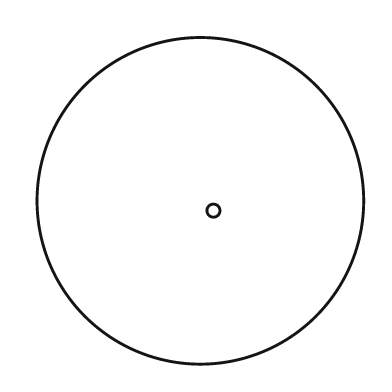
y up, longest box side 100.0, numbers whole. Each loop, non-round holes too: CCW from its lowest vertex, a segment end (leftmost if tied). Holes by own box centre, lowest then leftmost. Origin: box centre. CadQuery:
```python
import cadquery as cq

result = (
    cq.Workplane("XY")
    .moveTo(0.0, 0.0)
    .circle(50.0)
    .moveTo(4.0, -3.0)
    .circle(2.0)
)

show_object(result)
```